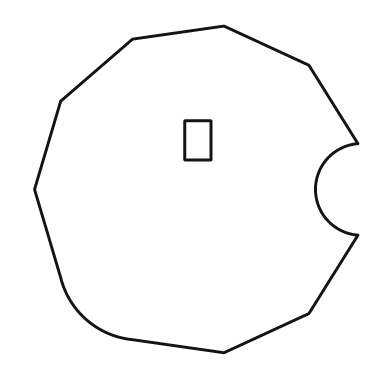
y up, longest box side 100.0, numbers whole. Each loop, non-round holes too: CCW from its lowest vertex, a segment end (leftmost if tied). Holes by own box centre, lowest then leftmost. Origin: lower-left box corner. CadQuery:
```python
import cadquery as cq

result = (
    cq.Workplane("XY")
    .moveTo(58.0, 0.0)
    .lineTo(84.0, 12.0)
    .lineTo(99.0, 36.0)
    .threePointArc((86.0, 50.0), (99.0, 64.0))
    .lineTo(84.0, 88.0)
    .lineTo(58.0, 100.0)
    .lineTo(30.0, 96.0)
    .lineTo(8.0, 77.0)
    .lineTo(0.0, 50.0)
    .lineTo(8.0, 23.0)
    .threePointArc((16.0, 10.0), (30.0, 4.0))
    .close()
    .moveTo(46.0, 59.0)
    .lineTo(54.0, 59.0)
    .lineTo(54.0, 71.0)
    .lineTo(46.0, 71.0)
    .close()
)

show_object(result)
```